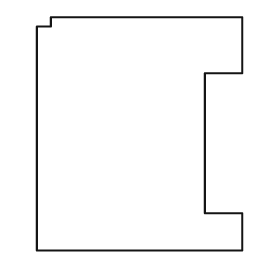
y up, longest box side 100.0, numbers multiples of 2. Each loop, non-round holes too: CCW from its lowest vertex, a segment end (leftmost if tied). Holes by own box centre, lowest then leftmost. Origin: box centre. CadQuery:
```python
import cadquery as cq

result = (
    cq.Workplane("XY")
    .moveTo(-44.0, -50.0)
    .lineTo(44.0, -50.0)
    .lineTo(44.0, -34.0)
    .lineTo(28.0, -34.0)
    .lineTo(28.0, 26.0)
    .lineTo(44.0, 26.0)
    .lineTo(44.0, 50.0)
    .lineTo(-38.0, 50.0)
    .lineTo(-38.0, 46.0)
    .lineTo(-44.0, 46.0)
    .close()
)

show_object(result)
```